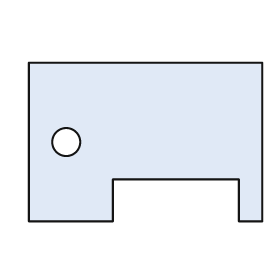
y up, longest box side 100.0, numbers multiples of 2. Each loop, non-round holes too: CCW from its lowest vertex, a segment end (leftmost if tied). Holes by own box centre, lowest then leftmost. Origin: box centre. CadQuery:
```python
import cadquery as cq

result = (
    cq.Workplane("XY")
    .moveTo(-50.0, -34.0)
    .lineTo(-14.0, -34.0)
    .lineTo(-14.0, -16.0)
    .lineTo(40.0, -16.0)
    .lineTo(40.0, -34.0)
    .lineTo(50.0, -34.0)
    .lineTo(50.0, 34.0)
    .lineTo(-50.0, 34.0)
    .close()
    .moveTo(-34.0, 0.0)
    .circle(6.0)
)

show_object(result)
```